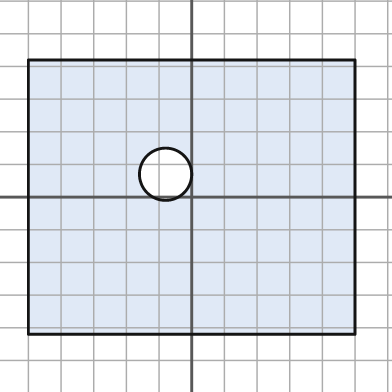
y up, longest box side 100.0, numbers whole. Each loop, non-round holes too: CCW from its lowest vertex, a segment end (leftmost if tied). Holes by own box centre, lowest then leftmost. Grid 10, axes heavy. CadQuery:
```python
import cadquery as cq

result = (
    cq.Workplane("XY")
    .moveTo(-50.0, -42.0)
    .lineTo(50.0, -42.0)
    .lineTo(50.0, 42.0)
    .lineTo(-50.0, 42.0)
    .close()
    .moveTo(-8.0, 7.0)
    .circle(8.0)
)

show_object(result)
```